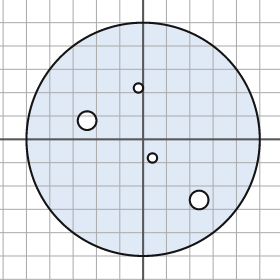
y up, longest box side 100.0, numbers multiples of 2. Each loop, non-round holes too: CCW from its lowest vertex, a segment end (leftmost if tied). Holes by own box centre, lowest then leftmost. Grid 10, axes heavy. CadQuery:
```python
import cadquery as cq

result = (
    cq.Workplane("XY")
    .moveTo(0.0, 0.0)
    .circle(50.0)
    .moveTo(24.0, -26.0)
    .circle(4.0)
    .moveTo(4.0, -8.0)
    .circle(2.0)
    .moveTo(-24.0, 8.0)
    .circle(4.0)
    .moveTo(-2.0, 22.0)
    .circle(2.0)
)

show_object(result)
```